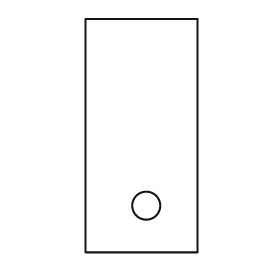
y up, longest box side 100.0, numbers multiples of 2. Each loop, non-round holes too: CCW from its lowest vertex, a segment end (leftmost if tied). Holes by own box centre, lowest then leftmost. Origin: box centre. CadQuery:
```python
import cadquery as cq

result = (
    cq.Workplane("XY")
    .moveTo(-24.0, -50.0)
    .lineTo(24.0, -50.0)
    .lineTo(24.0, 50.0)
    .lineTo(-24.0, 50.0)
    .close()
    .moveTo(2.0, -30.0)
    .circle(6.0)
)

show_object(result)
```